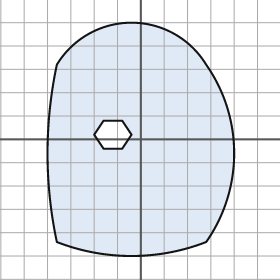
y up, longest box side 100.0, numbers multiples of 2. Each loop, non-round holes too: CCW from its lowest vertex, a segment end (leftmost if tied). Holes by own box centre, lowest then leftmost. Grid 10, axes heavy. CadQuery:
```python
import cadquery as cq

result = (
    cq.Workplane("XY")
    .moveTo(-36.0, -44.0)
    .threePointArc((-4.0, -50.0), (28.0, -44.0))
    .threePointArc((40.0, -6.0), (28.0, 32.0))
    .threePointArc((-4.0, 50.0), (-36.0, 32.0))
    .threePointArc((-40.0, -6.0), (-36.0, -44.0))
    .close()
    .moveTo(-16.0, -4.0)
    .lineTo(-8.0, -4.0)
    .lineTo(-4.0, 2.0)
    .lineTo(-8.0, 8.0)
    .lineTo(-16.0, 8.0)
    .lineTo(-20.0, 2.0)
    .close()
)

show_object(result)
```